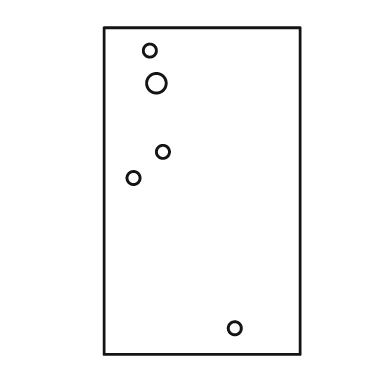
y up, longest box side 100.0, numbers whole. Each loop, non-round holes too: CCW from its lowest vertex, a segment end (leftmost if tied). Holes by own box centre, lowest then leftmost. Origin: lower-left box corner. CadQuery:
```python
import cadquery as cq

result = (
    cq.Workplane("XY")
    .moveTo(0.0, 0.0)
    .lineTo(60.0, 0.0)
    .lineTo(60.0, 100.0)
    .lineTo(0.0, 100.0)
    .close()
    .moveTo(40.0, 8.0)
    .circle(2.0)
    .moveTo(9.0, 54.0)
    .circle(2.0)
    .moveTo(18.0, 62.0)
    .circle(2.0)
    .moveTo(16.0, 83.0)
    .circle(3.0)
    .moveTo(14.0, 93.0)
    .circle(2.0)
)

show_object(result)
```